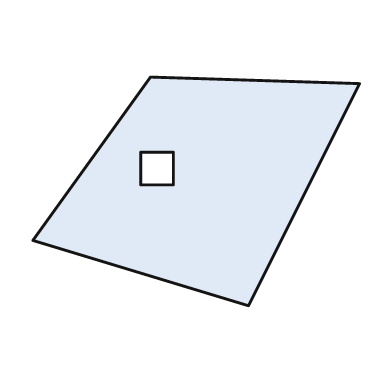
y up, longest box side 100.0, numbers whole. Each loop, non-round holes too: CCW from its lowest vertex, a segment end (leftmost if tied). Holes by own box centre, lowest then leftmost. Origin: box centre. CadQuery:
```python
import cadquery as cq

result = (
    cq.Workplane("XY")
    .moveTo(16.0, -35.0)
    .lineTo(50.0, 33.0)
    .lineTo(-14.0, 35.0)
    .lineTo(-50.0, -15.0)
    .close()
    .moveTo(-17.0, 2.0)
    .lineTo(-7.0, 2.0)
    .lineTo(-7.0, 12.0)
    .lineTo(-17.0, 12.0)
    .close()
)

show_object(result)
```